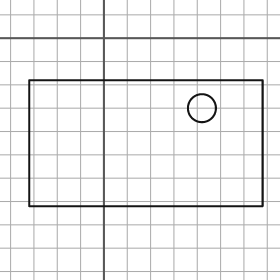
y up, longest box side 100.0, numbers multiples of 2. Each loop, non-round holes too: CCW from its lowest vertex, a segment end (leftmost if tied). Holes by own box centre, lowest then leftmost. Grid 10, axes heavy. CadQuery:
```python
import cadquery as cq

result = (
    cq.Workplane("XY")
    .moveTo(-32.0, -72.0)
    .lineTo(68.0, -72.0)
    .lineTo(68.0, -18.0)
    .lineTo(-32.0, -18.0)
    .close()
    .moveTo(42.0, -30.0)
    .circle(6.0)
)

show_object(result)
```